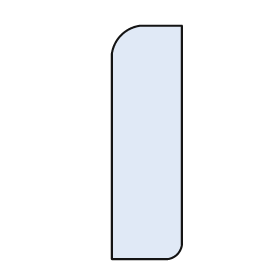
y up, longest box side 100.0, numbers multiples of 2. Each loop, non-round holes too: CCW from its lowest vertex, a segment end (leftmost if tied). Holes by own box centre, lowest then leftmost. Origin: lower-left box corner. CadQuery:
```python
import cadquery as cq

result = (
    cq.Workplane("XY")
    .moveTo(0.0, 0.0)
    .lineTo(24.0, 0.0)
    .threePointArc((28.0, 2.0), (30.0, 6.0))
    .lineTo(30.0, 100.0)
    .lineTo(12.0, 100.0)
    .threePointArc((4.0, 96.0), (0.0, 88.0))
    .close()
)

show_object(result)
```